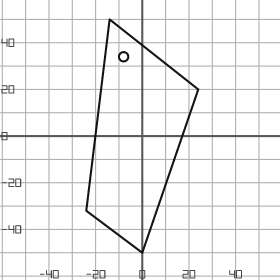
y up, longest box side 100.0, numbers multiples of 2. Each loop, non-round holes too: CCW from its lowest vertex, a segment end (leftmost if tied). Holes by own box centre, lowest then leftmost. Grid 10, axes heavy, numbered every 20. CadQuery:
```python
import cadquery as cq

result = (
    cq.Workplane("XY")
    .moveTo(0.0, -50.0)
    .lineTo(24.0, 20.0)
    .lineTo(-14.0, 50.0)
    .lineTo(-24.0, -32.0)
    .close()
    .moveTo(-8.0, 34.0)
    .circle(2.0)
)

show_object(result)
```